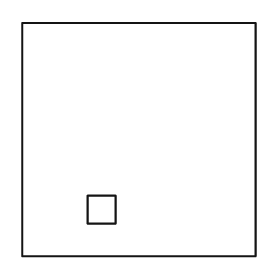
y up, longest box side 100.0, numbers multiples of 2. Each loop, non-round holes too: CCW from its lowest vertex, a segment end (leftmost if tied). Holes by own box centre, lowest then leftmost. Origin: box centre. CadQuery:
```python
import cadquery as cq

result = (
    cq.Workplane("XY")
    .moveTo(-50.0, -50.0)
    .lineTo(50.0, -50.0)
    .lineTo(50.0, 50.0)
    .lineTo(-50.0, 50.0)
    .close()
    .moveTo(-22.0, -36.0)
    .lineTo(-10.0, -36.0)
    .lineTo(-10.0, -24.0)
    .lineTo(-22.0, -24.0)
    .close()
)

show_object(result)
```